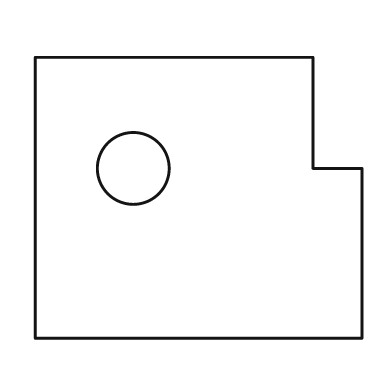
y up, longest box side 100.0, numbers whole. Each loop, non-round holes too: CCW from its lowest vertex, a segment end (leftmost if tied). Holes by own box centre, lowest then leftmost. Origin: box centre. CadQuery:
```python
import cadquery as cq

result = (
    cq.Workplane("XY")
    .moveTo(-50.0, -43.0)
    .lineTo(50.0, -43.0)
    .lineTo(50.0, 9.0)
    .lineTo(35.0, 9.0)
    .lineTo(35.0, 43.0)
    .lineTo(-50.0, 43.0)
    .close()
    .moveTo(-20.0, 9.0)
    .circle(11.0)
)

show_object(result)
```